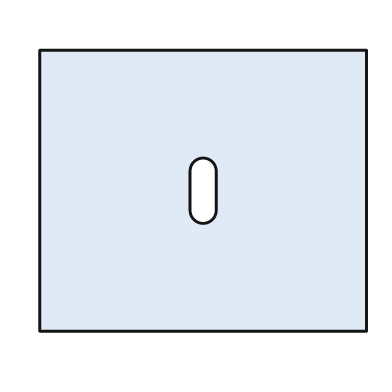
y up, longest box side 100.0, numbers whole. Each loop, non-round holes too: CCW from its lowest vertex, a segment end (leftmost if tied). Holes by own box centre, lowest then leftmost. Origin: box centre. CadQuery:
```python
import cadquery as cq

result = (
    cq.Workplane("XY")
    .moveTo(-50.0, -43.0)
    .lineTo(50.0, -43.0)
    .lineTo(50.0, 43.0)
    .lineTo(-50.0, 43.0)
    .close()
    .moveTo(-4.0, -6.0)
    .threePointArc((0.0, -10.0), (4.0, -6.0))
    .lineTo(4.0, 6.0)
    .threePointArc((0.0, 10.0), (-4.0, 6.0))
    .close()
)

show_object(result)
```